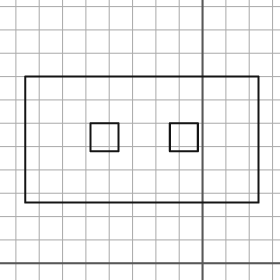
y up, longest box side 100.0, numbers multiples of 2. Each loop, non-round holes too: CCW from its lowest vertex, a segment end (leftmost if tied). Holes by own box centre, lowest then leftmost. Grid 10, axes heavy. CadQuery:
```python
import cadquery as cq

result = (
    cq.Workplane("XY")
    .moveTo(-76.0, 26.0)
    .lineTo(24.0, 26.0)
    .lineTo(24.0, 80.0)
    .lineTo(-76.0, 80.0)
    .close()
    .moveTo(-48.0, 48.0)
    .lineTo(-36.0, 48.0)
    .lineTo(-36.0, 60.0)
    .lineTo(-48.0, 60.0)
    .close()
    .moveTo(-14.0, 48.0)
    .lineTo(-2.0, 48.0)
    .lineTo(-2.0, 60.0)
    .lineTo(-14.0, 60.0)
    .close()
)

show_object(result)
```